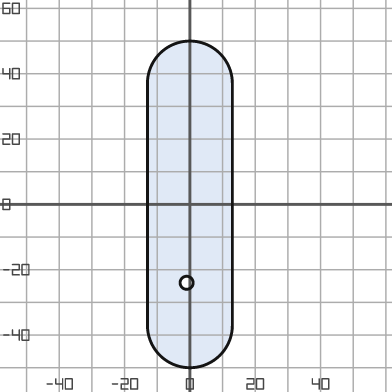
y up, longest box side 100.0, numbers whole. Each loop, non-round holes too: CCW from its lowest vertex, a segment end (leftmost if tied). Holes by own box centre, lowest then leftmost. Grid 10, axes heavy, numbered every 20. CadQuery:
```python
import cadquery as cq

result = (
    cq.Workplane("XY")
    .moveTo(-13.0, -37.0)
    .threePointArc((0.0, -50.0), (13.0, -37.0))
    .lineTo(13.0, 37.0)
    .threePointArc((0.0, 50.0), (-13.0, 37.0))
    .close()
    .moveTo(-1.0, -24.0)
    .circle(2.0)
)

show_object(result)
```